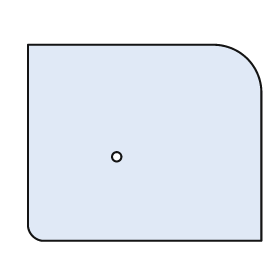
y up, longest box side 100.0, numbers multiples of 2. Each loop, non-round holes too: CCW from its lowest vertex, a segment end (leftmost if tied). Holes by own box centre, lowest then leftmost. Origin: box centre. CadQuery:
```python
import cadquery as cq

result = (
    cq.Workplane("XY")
    .moveTo(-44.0, -42.0)
    .lineTo(50.0, -42.0)
    .lineTo(50.0, 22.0)
    .threePointArc((44.0, 36.0), (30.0, 42.0))
    .lineTo(-50.0, 42.0)
    .lineTo(-50.0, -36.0)
    .threePointArc((-48.0, -40.0), (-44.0, -42.0))
    .close()
    .moveTo(-12.0, -6.0)
    .circle(2.0)
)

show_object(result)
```